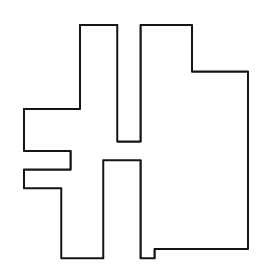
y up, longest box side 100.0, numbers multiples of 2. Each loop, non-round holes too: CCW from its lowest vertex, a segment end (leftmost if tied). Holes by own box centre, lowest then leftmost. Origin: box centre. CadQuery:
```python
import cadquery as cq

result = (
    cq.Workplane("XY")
    .moveTo(-32.0, -50.0)
    .lineTo(-14.0, -50.0)
    .lineTo(-14.0, -8.0)
    .lineTo(2.0, -8.0)
    .lineTo(2.0, -50.0)
    .lineTo(8.0, -50.0)
    .lineTo(8.0, -46.0)
    .lineTo(48.0, -46.0)
    .lineTo(48.0, 30.0)
    .lineTo(24.0, 30.0)
    .lineTo(24.0, 50.0)
    .lineTo(2.0, 50.0)
    .lineTo(2.0, 0.0)
    .lineTo(-8.0, 0.0)
    .lineTo(-8.0, 50.0)
    .lineTo(-24.0, 50.0)
    .lineTo(-24.0, 14.0)
    .lineTo(-48.0, 14.0)
    .lineTo(-48.0, -4.0)
    .lineTo(-28.0, -4.0)
    .lineTo(-28.0, -12.0)
    .lineTo(-48.0, -12.0)
    .lineTo(-48.0, -20.0)
    .lineTo(-32.0, -20.0)
    .close()
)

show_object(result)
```